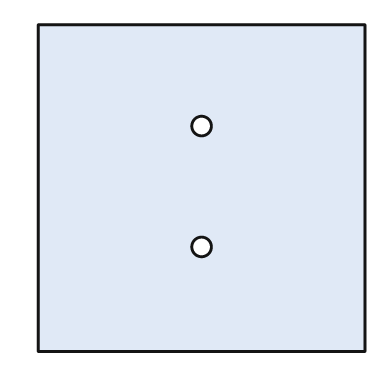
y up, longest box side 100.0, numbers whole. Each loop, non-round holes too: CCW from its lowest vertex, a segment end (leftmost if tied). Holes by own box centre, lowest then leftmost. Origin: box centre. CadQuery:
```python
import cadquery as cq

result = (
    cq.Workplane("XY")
    .moveTo(-50.0, -50.0)
    .lineTo(50.0, -50.0)
    .lineTo(50.0, 50.0)
    .lineTo(-50.0, 50.0)
    .close()
    .moveTo(0.0, -18.0)
    .circle(3.0)
    .moveTo(0.0, 19.0)
    .circle(3.0)
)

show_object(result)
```